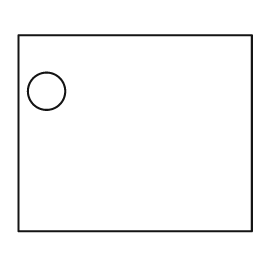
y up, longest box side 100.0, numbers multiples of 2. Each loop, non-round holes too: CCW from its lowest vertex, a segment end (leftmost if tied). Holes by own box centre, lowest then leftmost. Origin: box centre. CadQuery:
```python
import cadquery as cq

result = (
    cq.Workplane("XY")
    .moveTo(-50.0, -42.0)
    .lineTo(50.0, -42.0)
    .lineTo(50.0, 42.0)
    .lineTo(-50.0, 42.0)
    .close()
    .moveTo(-38.0, 18.0)
    .circle(8.0)
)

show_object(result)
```